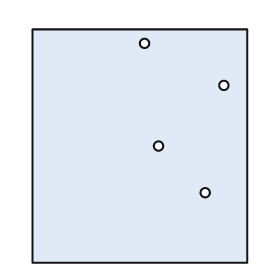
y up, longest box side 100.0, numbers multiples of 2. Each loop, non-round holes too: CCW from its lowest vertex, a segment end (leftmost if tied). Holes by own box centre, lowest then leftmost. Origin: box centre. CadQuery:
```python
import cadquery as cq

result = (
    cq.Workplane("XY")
    .moveTo(-46.0, -50.0)
    .lineTo(46.0, -50.0)
    .lineTo(46.0, 50.0)
    .lineTo(-46.0, 50.0)
    .close()
    .moveTo(28.0, -20.0)
    .circle(2.0)
    .moveTo(8.0, 0.0)
    .circle(2.0)
    .moveTo(36.0, 26.0)
    .circle(2.0)
    .moveTo(2.0, 44.0)
    .circle(2.0)
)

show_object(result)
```